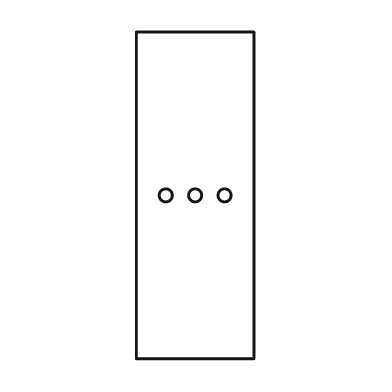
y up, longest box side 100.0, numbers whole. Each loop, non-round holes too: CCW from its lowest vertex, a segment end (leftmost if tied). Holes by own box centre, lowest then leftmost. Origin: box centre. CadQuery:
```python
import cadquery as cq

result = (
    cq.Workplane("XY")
    .moveTo(-18.0, -50.0)
    .lineTo(18.0, -50.0)
    .lineTo(18.0, 50.0)
    .lineTo(-18.0, 50.0)
    .close()
    .moveTo(-9.0, 0.0)
    .circle(2.0)
    .moveTo(0.0, 0.0)
    .circle(2.0)
    .moveTo(9.0, 0.0)
    .circle(2.0)
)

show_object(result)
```